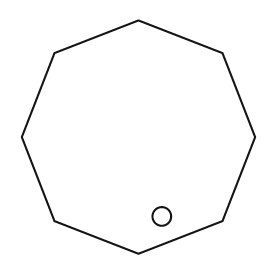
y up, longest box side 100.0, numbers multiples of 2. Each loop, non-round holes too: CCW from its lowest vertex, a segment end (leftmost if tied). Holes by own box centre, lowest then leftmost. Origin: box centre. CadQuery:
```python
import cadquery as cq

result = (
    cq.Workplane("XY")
    .moveTo(0.0, -50.0)
    .lineTo(36.0, -36.0)
    .lineTo(50.0, 0.0)
    .lineTo(36.0, 36.0)
    .lineTo(0.0, 50.0)
    .lineTo(-36.0, 36.0)
    .lineTo(-50.0, 0.0)
    .lineTo(-36.0, -36.0)
    .close()
    .moveTo(10.0, -34.0)
    .circle(4.0)
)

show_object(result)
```